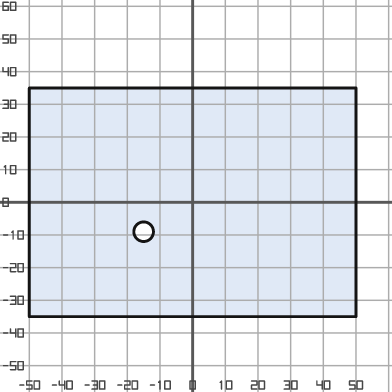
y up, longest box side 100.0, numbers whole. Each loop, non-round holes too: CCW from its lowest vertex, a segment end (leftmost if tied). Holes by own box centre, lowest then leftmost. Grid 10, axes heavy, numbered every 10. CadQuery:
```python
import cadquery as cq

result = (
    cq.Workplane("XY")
    .moveTo(-50.0, -35.0)
    .lineTo(50.0, -35.0)
    .lineTo(50.0, 35.0)
    .lineTo(-50.0, 35.0)
    .close()
    .moveTo(-15.0, -9.0)
    .circle(3.0)
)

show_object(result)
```